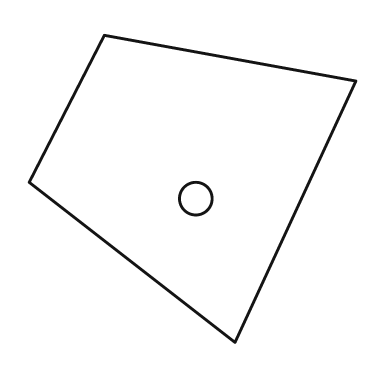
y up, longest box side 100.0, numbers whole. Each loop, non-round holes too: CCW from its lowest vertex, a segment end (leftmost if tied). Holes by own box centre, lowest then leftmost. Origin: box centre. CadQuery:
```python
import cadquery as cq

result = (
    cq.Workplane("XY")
    .moveTo(13.0, -47.0)
    .lineTo(50.0, 33.0)
    .lineTo(-27.0, 47.0)
    .lineTo(-50.0, 2.0)
    .close()
    .moveTo(1.0, -3.0)
    .circle(5.0)
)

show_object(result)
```